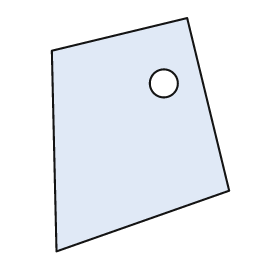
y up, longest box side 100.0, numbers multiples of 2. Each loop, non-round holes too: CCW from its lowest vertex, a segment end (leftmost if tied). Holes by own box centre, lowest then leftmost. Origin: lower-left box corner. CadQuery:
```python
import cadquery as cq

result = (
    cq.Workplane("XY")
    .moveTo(2.0, 0.0)
    .lineTo(76.0, 26.0)
    .lineTo(58.0, 100.0)
    .lineTo(0.0, 86.0)
    .close()
    .moveTo(48.0, 72.0)
    .circle(6.0)
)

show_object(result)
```